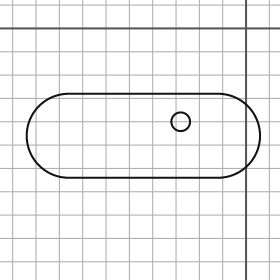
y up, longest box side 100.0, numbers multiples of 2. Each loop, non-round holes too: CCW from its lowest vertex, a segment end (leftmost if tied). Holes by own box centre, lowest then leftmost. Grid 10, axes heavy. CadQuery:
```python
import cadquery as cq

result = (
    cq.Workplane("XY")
    .moveTo(-76.0, -64.0)
    .lineTo(-12.0, -64.0)
    .threePointArc((6.0, -46.0), (-12.0, -28.0))
    .lineTo(-76.0, -28.0)
    .threePointArc((-94.0, -46.0), (-76.0, -64.0))
    .close()
    .moveTo(-28.0, -40.0)
    .circle(4.0)
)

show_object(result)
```